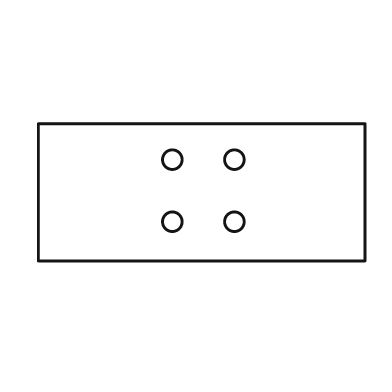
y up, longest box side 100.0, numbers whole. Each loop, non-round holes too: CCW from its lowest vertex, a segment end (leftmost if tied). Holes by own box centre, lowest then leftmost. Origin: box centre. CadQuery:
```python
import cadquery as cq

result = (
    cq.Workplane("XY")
    .moveTo(-50.0, -21.0)
    .lineTo(50.0, -21.0)
    .lineTo(50.0, 21.0)
    .lineTo(-50.0, 21.0)
    .close()
    .moveTo(-9.0, -9.0)
    .circle(3.0)
    .moveTo(10.0, -9.0)
    .circle(3.0)
    .moveTo(-9.0, 10.0)
    .circle(3.0)
    .moveTo(10.0, 10.0)
    .circle(3.0)
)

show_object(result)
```